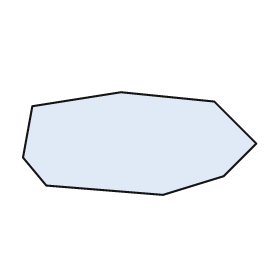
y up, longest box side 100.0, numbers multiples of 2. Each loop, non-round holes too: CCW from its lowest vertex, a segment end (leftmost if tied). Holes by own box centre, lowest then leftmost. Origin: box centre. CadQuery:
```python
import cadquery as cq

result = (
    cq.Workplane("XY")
    .moveTo(10.0, -22.0)
    .lineTo(36.0, -14.0)
    .lineTo(50.0, 0.0)
    .lineTo(32.0, 18.0)
    .lineTo(-8.0, 22.0)
    .lineTo(-46.0, 16.0)
    .lineTo(-50.0, -6.0)
    .lineTo(-40.0, -18.0)
    .close()
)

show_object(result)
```